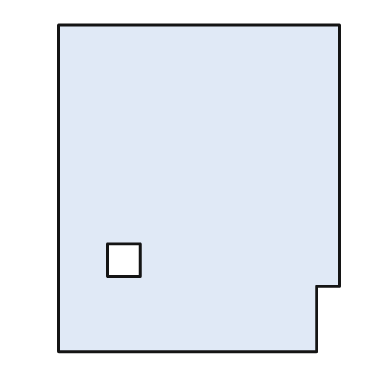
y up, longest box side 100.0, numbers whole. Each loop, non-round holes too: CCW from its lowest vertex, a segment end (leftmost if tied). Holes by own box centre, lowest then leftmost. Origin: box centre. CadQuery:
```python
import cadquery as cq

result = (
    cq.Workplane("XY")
    .moveTo(-43.0, -50.0)
    .lineTo(36.0, -50.0)
    .lineTo(36.0, -30.0)
    .lineTo(43.0, -30.0)
    .lineTo(43.0, 50.0)
    .lineTo(-43.0, 50.0)
    .close()
    .moveTo(-28.0, -27.0)
    .lineTo(-18.0, -27.0)
    .lineTo(-18.0, -17.0)
    .lineTo(-28.0, -17.0)
    .close()
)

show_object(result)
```